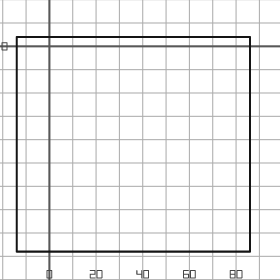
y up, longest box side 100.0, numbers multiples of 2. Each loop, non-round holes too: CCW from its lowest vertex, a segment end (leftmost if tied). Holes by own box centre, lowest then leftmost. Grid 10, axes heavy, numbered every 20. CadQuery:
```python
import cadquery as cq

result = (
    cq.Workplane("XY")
    .moveTo(-14.0, -88.0)
    .lineTo(86.0, -88.0)
    .lineTo(86.0, 4.0)
    .lineTo(-14.0, 4.0)
    .close()
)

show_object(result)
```